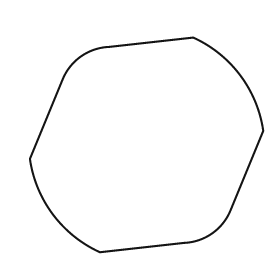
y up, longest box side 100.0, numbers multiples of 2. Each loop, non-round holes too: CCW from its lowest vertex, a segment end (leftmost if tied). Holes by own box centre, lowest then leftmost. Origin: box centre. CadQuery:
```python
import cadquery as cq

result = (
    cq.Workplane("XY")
    .moveTo(-20.0, -46.0)
    .lineTo(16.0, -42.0)
    .threePointArc((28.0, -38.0), (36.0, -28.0))
    .lineTo(50.0, 6.0)
    .threePointArc((40.0, 30.0), (20.0, 46.0))
    .lineTo(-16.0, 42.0)
    .threePointArc((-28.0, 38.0), (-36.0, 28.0))
    .lineTo(-50.0, -6.0)
    .threePointArc((-40.0, -30.0), (-20.0, -46.0))
    .close()
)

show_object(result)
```